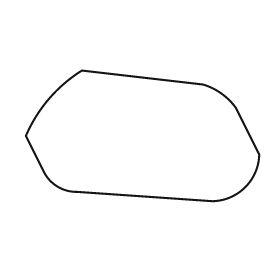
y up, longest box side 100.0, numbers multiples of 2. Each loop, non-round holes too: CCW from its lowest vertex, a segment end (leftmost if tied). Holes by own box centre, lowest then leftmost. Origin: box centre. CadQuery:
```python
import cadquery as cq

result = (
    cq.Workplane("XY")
    .moveTo(30.0, -28.0)
    .threePointArc((44.0, -22.0), (50.0, -8.0))
    .lineTo(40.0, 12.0)
    .threePointArc((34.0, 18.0), (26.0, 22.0))
    .lineTo(-26.0, 28.0)
    .threePointArc((-40.0, 16.0), (-50.0, 0.0))
    .lineTo(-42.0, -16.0)
    .threePointArc((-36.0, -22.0), (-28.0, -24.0))
    .close()
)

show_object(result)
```